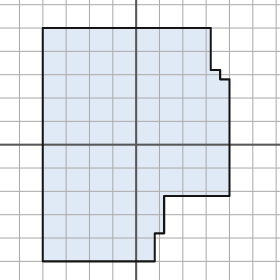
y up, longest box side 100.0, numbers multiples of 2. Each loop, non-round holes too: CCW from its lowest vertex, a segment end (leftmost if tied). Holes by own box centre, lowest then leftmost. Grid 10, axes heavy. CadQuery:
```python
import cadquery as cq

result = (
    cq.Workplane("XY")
    .moveTo(-40.0, -50.0)
    .lineTo(8.0, -50.0)
    .lineTo(8.0, -38.0)
    .lineTo(12.0, -38.0)
    .lineTo(12.0, -22.0)
    .lineTo(40.0, -22.0)
    .lineTo(40.0, 28.0)
    .lineTo(36.0, 28.0)
    .lineTo(36.0, 32.0)
    .lineTo(32.0, 32.0)
    .lineTo(32.0, 50.0)
    .lineTo(-40.0, 50.0)
    .close()
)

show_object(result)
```